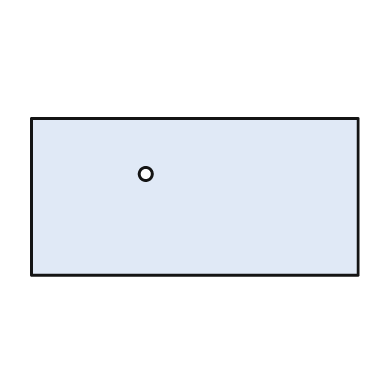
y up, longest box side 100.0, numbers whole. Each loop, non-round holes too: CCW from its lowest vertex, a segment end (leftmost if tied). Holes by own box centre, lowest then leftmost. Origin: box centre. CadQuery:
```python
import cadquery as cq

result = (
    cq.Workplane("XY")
    .moveTo(-50.0, -24.0)
    .lineTo(50.0, -24.0)
    .lineTo(50.0, 24.0)
    .lineTo(-50.0, 24.0)
    .close()
    .moveTo(-15.0, 7.0)
    .circle(2.0)
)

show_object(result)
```